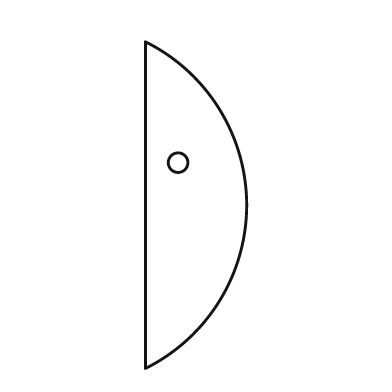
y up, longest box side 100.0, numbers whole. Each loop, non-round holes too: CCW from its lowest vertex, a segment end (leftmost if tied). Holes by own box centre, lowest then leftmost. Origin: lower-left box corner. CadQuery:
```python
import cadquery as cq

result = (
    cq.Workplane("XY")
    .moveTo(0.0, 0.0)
    .threePointArc((31.0, 50.0), (0.0, 100.0))
    .close()
    .moveTo(10.0, 63.0)
    .circle(3.0)
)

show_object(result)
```